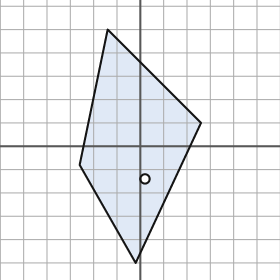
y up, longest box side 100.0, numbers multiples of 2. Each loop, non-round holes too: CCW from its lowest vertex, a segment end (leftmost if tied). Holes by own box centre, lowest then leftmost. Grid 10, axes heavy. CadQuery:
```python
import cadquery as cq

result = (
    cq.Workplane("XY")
    .moveTo(-2.0, -50.0)
    .lineTo(26.0, 10.0)
    .lineTo(-14.0, 50.0)
    .lineTo(-26.0, -8.0)
    .close()
    .moveTo(2.0, -14.0)
    .circle(2.0)
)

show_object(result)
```